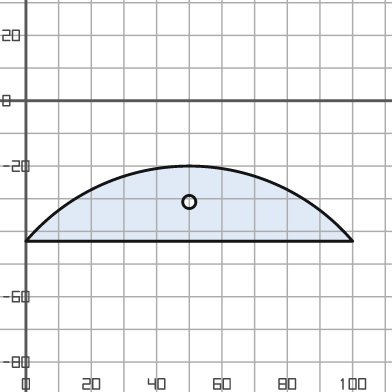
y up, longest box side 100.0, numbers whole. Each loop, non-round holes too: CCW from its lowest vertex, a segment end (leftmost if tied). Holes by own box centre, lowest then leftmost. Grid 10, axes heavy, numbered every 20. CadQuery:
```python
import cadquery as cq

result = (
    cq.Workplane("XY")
    .moveTo(0.0, -43.0)
    .lineTo(100.0, -43.0)
    .threePointArc((50.0, -20.0), (0.0, -43.0))
    .close()
    .moveTo(50.0, -31.0)
    .circle(2.0)
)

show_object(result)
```